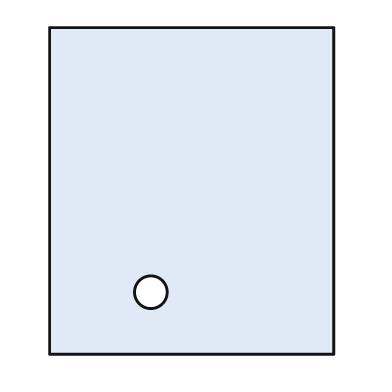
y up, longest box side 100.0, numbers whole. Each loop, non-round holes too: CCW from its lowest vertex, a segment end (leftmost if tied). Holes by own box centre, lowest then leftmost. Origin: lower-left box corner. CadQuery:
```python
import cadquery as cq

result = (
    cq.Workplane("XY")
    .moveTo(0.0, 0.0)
    .lineTo(87.0, 0.0)
    .lineTo(87.0, 100.0)
    .lineTo(0.0, 100.0)
    .close()
    .moveTo(31.0, 19.0)
    .circle(5.0)
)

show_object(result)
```